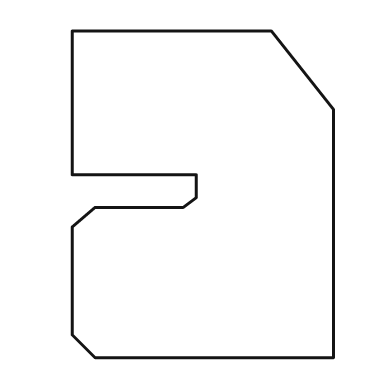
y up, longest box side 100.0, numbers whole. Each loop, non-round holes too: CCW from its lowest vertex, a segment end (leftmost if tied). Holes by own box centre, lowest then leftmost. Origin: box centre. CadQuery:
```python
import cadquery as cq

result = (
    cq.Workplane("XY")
    .moveTo(-33.0, -50.0)
    .lineTo(40.0, -50.0)
    .lineTo(40.0, 26.0)
    .lineTo(21.0, 50.0)
    .lineTo(-40.0, 50.0)
    .lineTo(-40.0, 6.0)
    .lineTo(-2.0, 6.0)
    .lineTo(-2.0, -1.0)
    .lineTo(-6.0, -4.0)
    .lineTo(-33.0, -4.0)
    .lineTo(-40.0, -10.0)
    .lineTo(-40.0, -43.0)
    .close()
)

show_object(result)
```